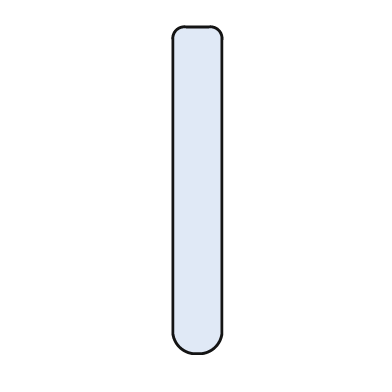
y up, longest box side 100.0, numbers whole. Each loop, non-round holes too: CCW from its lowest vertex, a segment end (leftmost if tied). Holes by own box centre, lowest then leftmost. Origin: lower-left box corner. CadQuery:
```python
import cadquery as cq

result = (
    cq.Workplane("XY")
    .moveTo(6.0, 0.0)
    .lineTo(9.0, 0.0)
    .threePointArc((13.0, 2.0), (15.0, 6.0))
    .lineTo(15.0, 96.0)
    .threePointArc((14.0, 99.0), (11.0, 100.0))
    .lineTo(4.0, 100.0)
    .threePointArc((1.0, 99.0), (0.0, 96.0))
    .lineTo(0.0, 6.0)
    .threePointArc((2.0, 2.0), (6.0, 0.0))
    .close()
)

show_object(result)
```